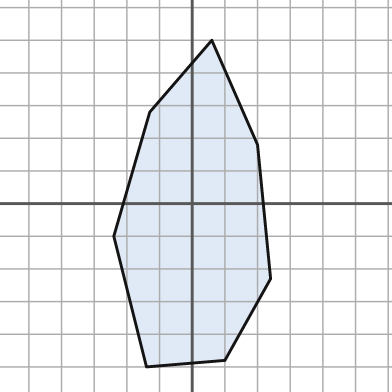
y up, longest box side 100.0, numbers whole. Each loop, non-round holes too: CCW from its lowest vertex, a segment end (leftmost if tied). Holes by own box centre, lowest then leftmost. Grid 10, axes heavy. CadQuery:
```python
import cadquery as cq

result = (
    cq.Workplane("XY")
    .moveTo(-14.0, -50.0)
    .lineTo(10.0, -48.0)
    .lineTo(24.0, -23.0)
    .lineTo(20.0, 18.0)
    .lineTo(6.0, 50.0)
    .lineTo(-13.0, 28.0)
    .lineTo(-24.0, -10.0)
    .close()
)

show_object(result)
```